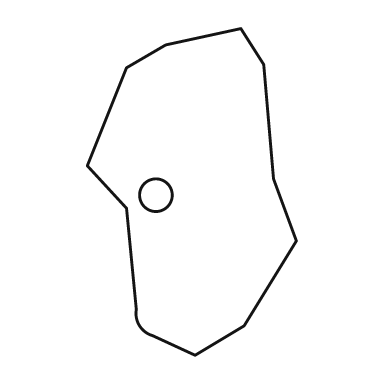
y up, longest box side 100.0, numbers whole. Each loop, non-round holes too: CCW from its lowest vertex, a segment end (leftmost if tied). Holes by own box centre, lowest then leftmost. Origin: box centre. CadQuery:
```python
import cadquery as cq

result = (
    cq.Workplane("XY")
    .moveTo(1.0, -50.0)
    .lineTo(16.0, -41.0)
    .lineTo(32.0, -15.0)
    .lineTo(25.0, 4.0)
    .lineTo(22.0, 39.0)
    .lineTo(15.0, 50.0)
    .lineTo(-8.0, 45.0)
    .lineTo(-20.0, 38.0)
    .lineTo(-32.0, 8.0)
    .lineTo(-20.0, -5.0)
    .lineTo(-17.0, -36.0)
    .threePointArc((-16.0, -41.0), (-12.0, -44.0))
    .close()
    .moveTo(-11.0, -1.0)
    .circle(5.0)
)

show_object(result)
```